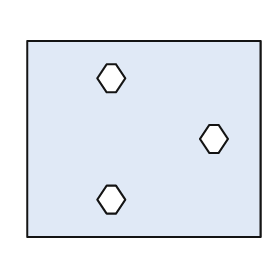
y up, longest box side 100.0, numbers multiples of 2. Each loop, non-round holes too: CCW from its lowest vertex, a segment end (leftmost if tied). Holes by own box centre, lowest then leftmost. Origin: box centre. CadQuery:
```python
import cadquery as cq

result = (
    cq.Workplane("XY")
    .moveTo(-50.0, -42.0)
    .lineTo(50.0, -42.0)
    .lineTo(50.0, 42.0)
    .lineTo(-50.0, 42.0)
    .close()
    .moveTo(-16.0, -32.0)
    .lineTo(-12.0, -32.0)
    .lineTo(-8.0, -26.0)
    .lineTo(-12.0, -20.0)
    .lineTo(-16.0, -20.0)
    .lineTo(-20.0, -26.0)
    .close()
    .moveTo(28.0, -6.0)
    .lineTo(32.0, -6.0)
    .lineTo(36.0, 0.0)
    .lineTo(32.0, 6.0)
    .lineTo(28.0, 6.0)
    .lineTo(24.0, 0.0)
    .close()
    .moveTo(-16.0, 20.0)
    .lineTo(-12.0, 20.0)
    .lineTo(-8.0, 26.0)
    .lineTo(-12.0, 32.0)
    .lineTo(-16.0, 32.0)
    .lineTo(-20.0, 26.0)
    .close()
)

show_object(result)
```